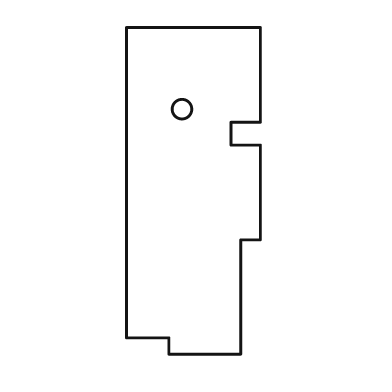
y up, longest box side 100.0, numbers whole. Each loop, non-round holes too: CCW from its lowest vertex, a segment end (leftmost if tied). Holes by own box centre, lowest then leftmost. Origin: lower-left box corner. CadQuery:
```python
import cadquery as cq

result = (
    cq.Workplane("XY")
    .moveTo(13.0, 0.0)
    .lineTo(35.0, 0.0)
    .lineTo(35.0, 35.0)
    .lineTo(41.0, 35.0)
    .lineTo(41.0, 64.0)
    .lineTo(32.0, 64.0)
    .lineTo(32.0, 71.0)
    .lineTo(41.0, 71.0)
    .lineTo(41.0, 100.0)
    .lineTo(0.0, 100.0)
    .lineTo(0.0, 5.0)
    .lineTo(13.0, 5.0)
    .close()
    .moveTo(17.0, 75.0)
    .circle(3.0)
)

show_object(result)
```